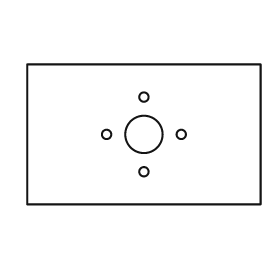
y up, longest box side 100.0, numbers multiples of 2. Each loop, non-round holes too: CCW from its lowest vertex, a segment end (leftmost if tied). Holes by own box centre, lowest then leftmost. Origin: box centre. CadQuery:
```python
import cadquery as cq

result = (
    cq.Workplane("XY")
    .moveTo(-50.0, -30.0)
    .lineTo(50.0, -30.0)
    .lineTo(50.0, 30.0)
    .lineTo(-50.0, 30.0)
    .close()
    .moveTo(0.0, -16.0)
    .circle(2.0)
    .moveTo(-16.0, 0.0)
    .circle(2.0)
    .moveTo(0.0, 0.0)
    .circle(8.0)
    .moveTo(16.0, 0.0)
    .circle(2.0)
    .moveTo(0.0, 16.0)
    .circle(2.0)
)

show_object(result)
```